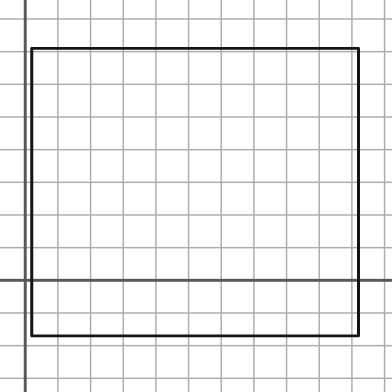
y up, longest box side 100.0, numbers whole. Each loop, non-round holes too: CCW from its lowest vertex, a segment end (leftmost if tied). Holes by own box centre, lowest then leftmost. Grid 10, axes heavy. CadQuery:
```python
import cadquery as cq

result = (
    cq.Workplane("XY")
    .moveTo(2.0, -17.0)
    .lineTo(102.0, -17.0)
    .lineTo(102.0, 71.0)
    .lineTo(2.0, 71.0)
    .close()
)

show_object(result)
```